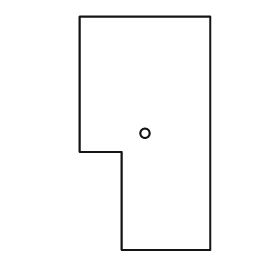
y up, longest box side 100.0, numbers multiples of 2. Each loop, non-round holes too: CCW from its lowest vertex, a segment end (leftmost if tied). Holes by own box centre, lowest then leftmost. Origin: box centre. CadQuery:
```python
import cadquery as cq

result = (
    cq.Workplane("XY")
    .moveTo(-10.0, -50.0)
    .lineTo(28.0, -50.0)
    .lineTo(28.0, 50.0)
    .lineTo(-28.0, 50.0)
    .lineTo(-28.0, -8.0)
    .lineTo(-10.0, -8.0)
    .close()
    .moveTo(0.0, 0.0)
    .circle(2.0)
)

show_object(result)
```